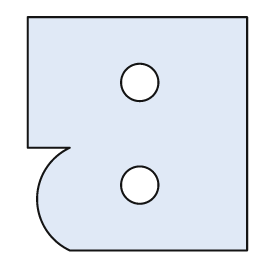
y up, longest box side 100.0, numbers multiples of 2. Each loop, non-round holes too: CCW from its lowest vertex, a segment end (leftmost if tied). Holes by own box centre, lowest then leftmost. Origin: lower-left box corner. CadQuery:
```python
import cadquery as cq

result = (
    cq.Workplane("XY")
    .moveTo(18.0, 0.0)
    .lineTo(94.0, 0.0)
    .lineTo(94.0, 100.0)
    .lineTo(0.0, 100.0)
    .lineTo(0.0, 44.0)
    .lineTo(18.0, 44.0)
    .threePointArc((4.0, 22.0), (18.0, 0.0))
    .close()
    .moveTo(48.0, 28.0)
    .circle(8.0)
    .moveTo(48.0, 72.0)
    .circle(8.0)
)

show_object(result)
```